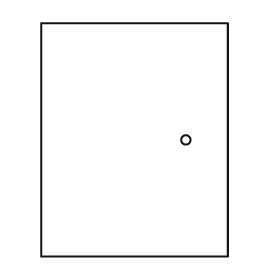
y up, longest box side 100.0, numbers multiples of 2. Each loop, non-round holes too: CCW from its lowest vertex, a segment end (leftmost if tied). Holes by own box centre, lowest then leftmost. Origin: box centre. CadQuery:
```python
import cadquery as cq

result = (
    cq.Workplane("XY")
    .moveTo(-40.0, -50.0)
    .lineTo(40.0, -50.0)
    .lineTo(40.0, 50.0)
    .lineTo(-40.0, 50.0)
    .close()
    .moveTo(22.0, 0.0)
    .circle(2.0)
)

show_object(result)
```